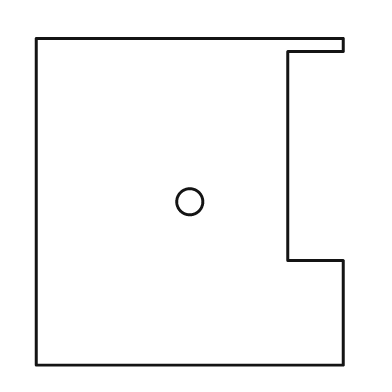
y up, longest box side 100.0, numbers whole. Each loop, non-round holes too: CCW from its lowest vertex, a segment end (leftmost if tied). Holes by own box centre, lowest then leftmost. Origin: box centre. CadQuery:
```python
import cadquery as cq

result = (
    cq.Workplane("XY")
    .moveTo(-47.0, -50.0)
    .lineTo(47.0, -50.0)
    .lineTo(47.0, -18.0)
    .lineTo(30.0, -18.0)
    .lineTo(30.0, 46.0)
    .lineTo(47.0, 46.0)
    .lineTo(47.0, 50.0)
    .lineTo(-47.0, 50.0)
    .close()
    .moveTo(0.0, 0.0)
    .circle(4.0)
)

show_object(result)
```